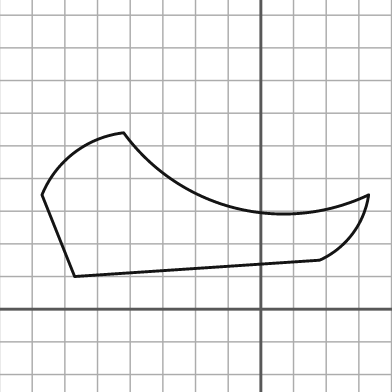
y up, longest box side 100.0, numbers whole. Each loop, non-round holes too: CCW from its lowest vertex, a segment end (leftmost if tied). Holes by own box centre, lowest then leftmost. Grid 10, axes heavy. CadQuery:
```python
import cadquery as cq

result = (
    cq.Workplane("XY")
    .moveTo(-57.0, 10.0)
    .lineTo(18.0, 15.0)
    .threePointArc((28.0, 23.0), (33.0, 35.0))
    .threePointArc((-8.0, 31.0), (-42.0, 54.0))
    .threePointArc((-57.0, 48.0), (-67.0, 35.0))
    .close()
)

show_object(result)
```